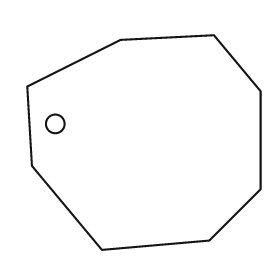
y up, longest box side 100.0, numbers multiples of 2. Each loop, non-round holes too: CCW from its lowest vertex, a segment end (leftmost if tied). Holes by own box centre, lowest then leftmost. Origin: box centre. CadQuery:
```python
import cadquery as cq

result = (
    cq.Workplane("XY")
    .moveTo(-18.0, -46.0)
    .lineTo(28.0, -42.0)
    .lineTo(50.0, -20.0)
    .lineTo(50.0, 22.0)
    .lineTo(30.0, 46.0)
    .lineTo(-10.0, 44.0)
    .lineTo(-50.0, 24.0)
    .lineTo(-48.0, -10.0)
    .close()
    .moveTo(-38.0, 8.0)
    .circle(4.0)
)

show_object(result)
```